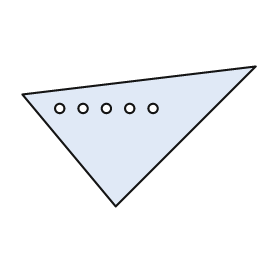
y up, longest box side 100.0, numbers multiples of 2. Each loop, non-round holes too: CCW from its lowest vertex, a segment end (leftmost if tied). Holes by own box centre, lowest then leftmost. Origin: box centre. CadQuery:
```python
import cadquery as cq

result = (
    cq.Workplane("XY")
    .moveTo(-10.0, -30.0)
    .lineTo(50.0, 30.0)
    .lineTo(-50.0, 18.0)
    .close()
    .moveTo(-34.0, 12.0)
    .circle(2.0)
    .moveTo(-24.0, 12.0)
    .circle(2.0)
    .moveTo(-14.0, 12.0)
    .circle(2.0)
    .moveTo(-4.0, 12.0)
    .circle(2.0)
    .moveTo(6.0, 12.0)
    .circle(2.0)
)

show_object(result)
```